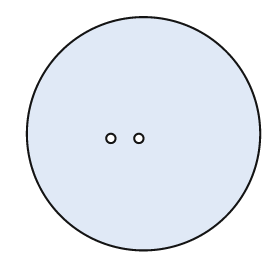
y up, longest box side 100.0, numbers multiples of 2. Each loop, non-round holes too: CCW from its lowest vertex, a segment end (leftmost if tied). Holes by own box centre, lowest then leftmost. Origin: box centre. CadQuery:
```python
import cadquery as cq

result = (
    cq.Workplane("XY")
    .moveTo(0.0, 0.0)
    .circle(50.0)
    .moveTo(-14.0, -2.0)
    .circle(2.0)
    .moveTo(-2.0, -2.0)
    .circle(2.0)
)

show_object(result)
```